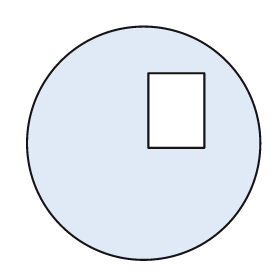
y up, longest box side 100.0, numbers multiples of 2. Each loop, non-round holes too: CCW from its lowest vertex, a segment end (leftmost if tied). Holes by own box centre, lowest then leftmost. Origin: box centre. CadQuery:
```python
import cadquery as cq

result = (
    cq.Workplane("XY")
    .moveTo(0.0, 0.0)
    .circle(50.0)
    .moveTo(2.0, -2.0)
    .lineTo(26.0, -2.0)
    .lineTo(26.0, 30.0)
    .lineTo(2.0, 30.0)
    .close()
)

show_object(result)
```